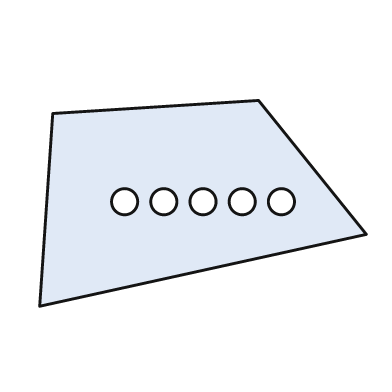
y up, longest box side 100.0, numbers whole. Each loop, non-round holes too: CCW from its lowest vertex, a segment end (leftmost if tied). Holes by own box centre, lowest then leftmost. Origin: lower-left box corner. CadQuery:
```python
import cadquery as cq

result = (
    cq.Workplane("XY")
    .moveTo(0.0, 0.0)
    .lineTo(100.0, 22.0)
    .lineTo(67.0, 63.0)
    .lineTo(4.0, 59.0)
    .close()
    .moveTo(26.0, 32.0)
    .circle(4.0)
    .moveTo(38.0, 32.0)
    .circle(4.0)
    .moveTo(50.0, 32.0)
    .circle(4.0)
    .moveTo(62.0, 32.0)
    .circle(4.0)
    .moveTo(74.0, 32.0)
    .circle(4.0)
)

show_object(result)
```